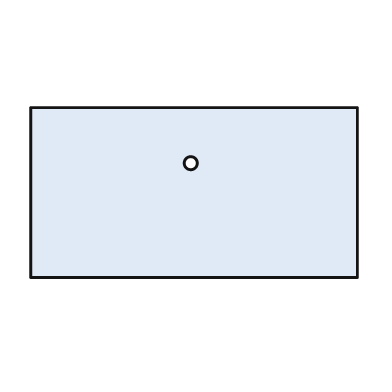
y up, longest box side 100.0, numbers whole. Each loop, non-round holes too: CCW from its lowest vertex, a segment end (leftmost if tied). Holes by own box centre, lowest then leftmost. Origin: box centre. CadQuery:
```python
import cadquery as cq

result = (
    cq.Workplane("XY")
    .moveTo(-50.0, -26.0)
    .lineTo(50.0, -26.0)
    .lineTo(50.0, 26.0)
    .lineTo(-50.0, 26.0)
    .close()
    .moveTo(-1.0, 9.0)
    .circle(2.0)
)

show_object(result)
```